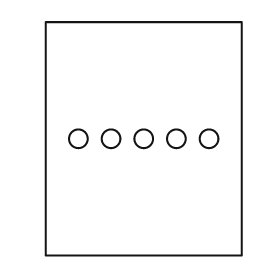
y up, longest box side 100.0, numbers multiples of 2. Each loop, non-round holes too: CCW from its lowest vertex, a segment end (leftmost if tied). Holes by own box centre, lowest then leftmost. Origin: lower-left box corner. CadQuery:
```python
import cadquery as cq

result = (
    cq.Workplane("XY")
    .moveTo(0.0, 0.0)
    .lineTo(84.0, 0.0)
    .lineTo(84.0, 100.0)
    .lineTo(0.0, 100.0)
    .close()
    .moveTo(14.0, 50.0)
    .circle(4.0)
    .moveTo(28.0, 50.0)
    .circle(4.0)
    .moveTo(42.0, 50.0)
    .circle(4.0)
    .moveTo(56.0, 50.0)
    .circle(4.0)
    .moveTo(70.0, 50.0)
    .circle(4.0)
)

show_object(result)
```